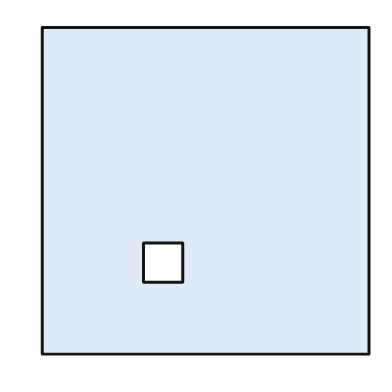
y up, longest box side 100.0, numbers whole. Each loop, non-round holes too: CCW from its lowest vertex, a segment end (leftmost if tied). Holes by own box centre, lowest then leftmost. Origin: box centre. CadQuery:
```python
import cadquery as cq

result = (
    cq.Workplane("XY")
    .moveTo(-50.0, -50.0)
    .lineTo(50.0, -50.0)
    .lineTo(50.0, 50.0)
    .lineTo(-50.0, 50.0)
    .close()
    .moveTo(-19.0, -28.0)
    .lineTo(-7.0, -28.0)
    .lineTo(-7.0, -16.0)
    .lineTo(-19.0, -16.0)
    .close()
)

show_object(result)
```